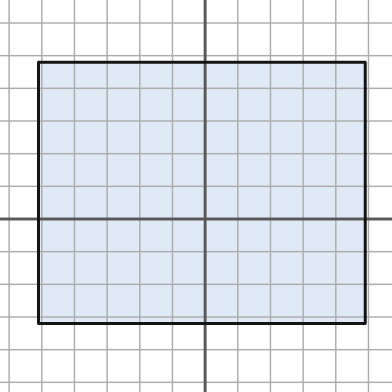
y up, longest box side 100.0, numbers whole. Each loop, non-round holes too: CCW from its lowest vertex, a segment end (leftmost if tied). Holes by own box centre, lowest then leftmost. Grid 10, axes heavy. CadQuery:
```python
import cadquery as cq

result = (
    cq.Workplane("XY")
    .moveTo(-51.0, -32.0)
    .lineTo(49.0, -32.0)
    .lineTo(49.0, 48.0)
    .lineTo(-51.0, 48.0)
    .close()
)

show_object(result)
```